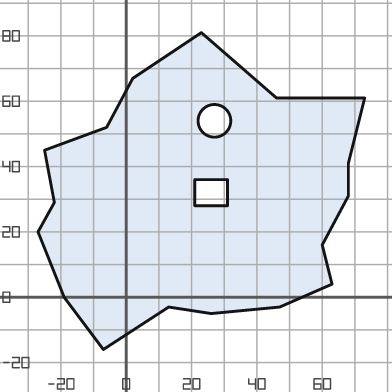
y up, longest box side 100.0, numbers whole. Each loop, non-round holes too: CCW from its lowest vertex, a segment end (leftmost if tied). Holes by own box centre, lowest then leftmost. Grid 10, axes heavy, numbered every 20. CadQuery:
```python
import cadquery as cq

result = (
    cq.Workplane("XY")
    .moveTo(-7.0, -16.0)
    .lineTo(13.0, -3.0)
    .lineTo(26.0, -5.0)
    .lineTo(47.0, -3.0)
    .lineTo(63.0, 4.0)
    .lineTo(60.0, 16.0)
    .lineTo(68.0, 31.0)
    .lineTo(68.0, 41.0)
    .lineTo(73.0, 61.0)
    .lineTo(46.0, 61.0)
    .lineTo(23.0, 81.0)
    .lineTo(2.0, 67.0)
    .lineTo(-6.0, 52.0)
    .lineTo(-25.0, 45.0)
    .lineTo(-22.0, 29.0)
    .lineTo(-27.0, 20.0)
    .lineTo(-19.0, 0.0)
    .close()
    .moveTo(21.0, 28.0)
    .lineTo(31.0, 28.0)
    .lineTo(31.0, 36.0)
    .lineTo(21.0, 36.0)
    .close()
    .moveTo(27.0, 54.0)
    .circle(5.0)
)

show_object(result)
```